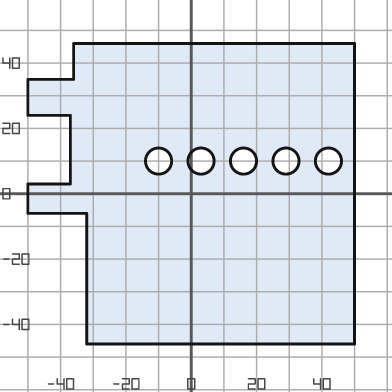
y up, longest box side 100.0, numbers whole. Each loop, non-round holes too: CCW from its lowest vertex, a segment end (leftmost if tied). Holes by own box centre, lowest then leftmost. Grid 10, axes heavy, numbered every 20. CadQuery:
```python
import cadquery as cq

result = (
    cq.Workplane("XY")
    .moveTo(-32.0, -46.0)
    .lineTo(50.0, -46.0)
    .lineTo(50.0, 46.0)
    .lineTo(-36.0, 46.0)
    .lineTo(-36.0, 35.0)
    .lineTo(-50.0, 35.0)
    .lineTo(-50.0, 24.0)
    .lineTo(-37.0, 24.0)
    .lineTo(-37.0, 3.0)
    .lineTo(-50.0, 3.0)
    .lineTo(-50.0, -6.0)
    .lineTo(-32.0, -6.0)
    .close()
    .moveTo(-10.0, 10.0)
    .circle(4.0)
    .moveTo(3.0, 10.0)
    .circle(4.0)
    .moveTo(16.0, 10.0)
    .circle(4.0)
    .moveTo(29.0, 10.0)
    .circle(4.0)
    .moveTo(42.0, 10.0)
    .circle(4.0)
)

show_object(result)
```